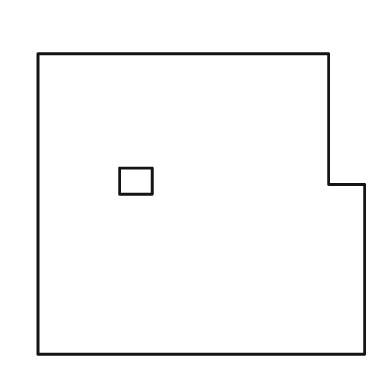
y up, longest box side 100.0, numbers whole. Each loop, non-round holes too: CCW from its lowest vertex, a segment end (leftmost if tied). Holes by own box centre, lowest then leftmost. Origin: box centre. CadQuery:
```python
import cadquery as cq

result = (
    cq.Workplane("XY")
    .moveTo(-50.0, -46.0)
    .lineTo(50.0, -46.0)
    .lineTo(50.0, 6.0)
    .lineTo(39.0, 6.0)
    .lineTo(39.0, 46.0)
    .lineTo(-50.0, 46.0)
    .close()
    .moveTo(-25.0, 3.0)
    .lineTo(-15.0, 3.0)
    .lineTo(-15.0, 11.0)
    .lineTo(-25.0, 11.0)
    .close()
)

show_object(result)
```